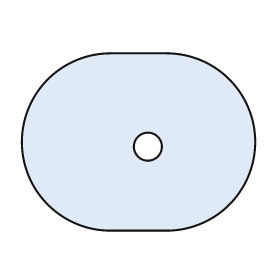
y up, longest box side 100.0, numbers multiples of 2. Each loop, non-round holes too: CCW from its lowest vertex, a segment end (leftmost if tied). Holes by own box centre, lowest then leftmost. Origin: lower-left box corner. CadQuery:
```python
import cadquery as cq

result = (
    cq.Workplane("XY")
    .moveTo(38.0, 0.0)
    .lineTo(62.0, 0.0)
    .threePointArc((100.0, 38.0), (62.0, 76.0))
    .lineTo(38.0, 76.0)
    .threePointArc((0.0, 38.0), (38.0, 0.0))
    .close()
    .moveTo(54.0, 36.0)
    .circle(6.0)
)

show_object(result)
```